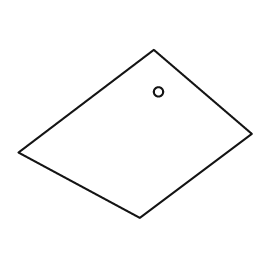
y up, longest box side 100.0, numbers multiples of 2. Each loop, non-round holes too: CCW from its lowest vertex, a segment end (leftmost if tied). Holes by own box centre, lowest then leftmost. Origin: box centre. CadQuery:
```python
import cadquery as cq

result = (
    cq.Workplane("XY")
    .moveTo(2.0, -36.0)
    .lineTo(50.0, 0.0)
    .lineTo(8.0, 36.0)
    .lineTo(-50.0, -8.0)
    .close()
    .moveTo(10.0, 18.0)
    .circle(2.0)
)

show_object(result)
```